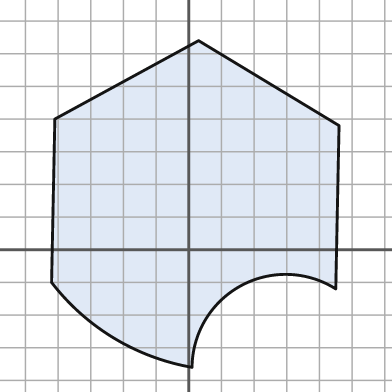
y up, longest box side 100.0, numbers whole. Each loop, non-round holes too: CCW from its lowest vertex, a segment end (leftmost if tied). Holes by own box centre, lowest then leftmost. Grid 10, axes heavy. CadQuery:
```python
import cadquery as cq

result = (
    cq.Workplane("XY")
    .moveTo(1.0, -36.0)
    .threePointArc((16.0, -11.0), (45.0, -12.0))
    .lineTo(46.0, 38.0)
    .lineTo(3.0, 64.0)
    .lineTo(-41.0, 40.0)
    .lineTo(-42.0, -10.0)
    .threePointArc((-23.0, -27.0), (1.0, -36.0))
    .close()
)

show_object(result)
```